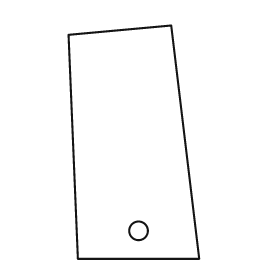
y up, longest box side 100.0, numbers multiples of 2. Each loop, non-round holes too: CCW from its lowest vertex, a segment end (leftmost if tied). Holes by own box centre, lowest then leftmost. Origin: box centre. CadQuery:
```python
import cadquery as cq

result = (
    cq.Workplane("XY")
    .moveTo(-24.0, -50.0)
    .lineTo(28.0, -50.0)
    .lineTo(16.0, 50.0)
    .lineTo(-28.0, 46.0)
    .close()
    .moveTo(2.0, -38.0)
    .circle(4.0)
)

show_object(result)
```